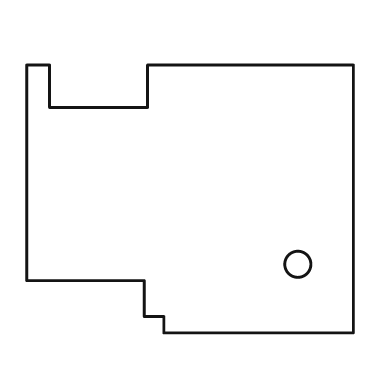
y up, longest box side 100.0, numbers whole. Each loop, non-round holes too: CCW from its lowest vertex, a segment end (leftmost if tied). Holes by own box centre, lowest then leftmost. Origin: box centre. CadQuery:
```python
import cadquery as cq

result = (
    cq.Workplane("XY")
    .moveTo(-8.0, -41.0)
    .lineTo(50.0, -41.0)
    .lineTo(50.0, 41.0)
    .lineTo(-13.0, 41.0)
    .lineTo(-13.0, 28.0)
    .lineTo(-43.0, 28.0)
    .lineTo(-43.0, 41.0)
    .lineTo(-50.0, 41.0)
    .lineTo(-50.0, -25.0)
    .lineTo(-14.0, -25.0)
    .lineTo(-14.0, -36.0)
    .lineTo(-8.0, -36.0)
    .close()
    .moveTo(33.0, -20.0)
    .circle(4.0)
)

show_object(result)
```